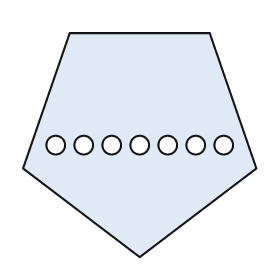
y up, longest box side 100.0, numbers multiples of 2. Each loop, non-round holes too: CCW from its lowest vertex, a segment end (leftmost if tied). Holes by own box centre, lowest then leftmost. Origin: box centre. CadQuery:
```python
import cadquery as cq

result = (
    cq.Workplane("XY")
    .moveTo(0.0, -48.0)
    .lineTo(50.0, -10.0)
    .lineTo(30.0, 48.0)
    .lineTo(-30.0, 48.0)
    .lineTo(-50.0, -10.0)
    .close()
    .moveTo(-36.0, 0.0)
    .circle(4.0)
    .moveTo(-24.0, 0.0)
    .circle(4.0)
    .moveTo(-12.0, 0.0)
    .circle(4.0)
    .moveTo(0.0, 0.0)
    .circle(4.0)
    .moveTo(12.0, 0.0)
    .circle(4.0)
    .moveTo(24.0, 0.0)
    .circle(4.0)
    .moveTo(36.0, 0.0)
    .circle(4.0)
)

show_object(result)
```